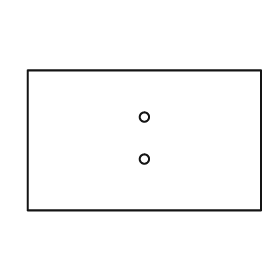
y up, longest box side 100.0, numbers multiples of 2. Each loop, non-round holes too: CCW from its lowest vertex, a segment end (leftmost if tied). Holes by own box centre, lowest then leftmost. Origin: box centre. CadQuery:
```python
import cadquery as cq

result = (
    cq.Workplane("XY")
    .moveTo(-50.0, -30.0)
    .lineTo(50.0, -30.0)
    .lineTo(50.0, 30.0)
    .lineTo(-50.0, 30.0)
    .close()
    .moveTo(0.0, -8.0)
    .circle(2.0)
    .moveTo(0.0, 10.0)
    .circle(2.0)
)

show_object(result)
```